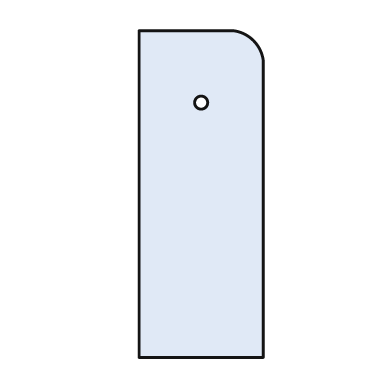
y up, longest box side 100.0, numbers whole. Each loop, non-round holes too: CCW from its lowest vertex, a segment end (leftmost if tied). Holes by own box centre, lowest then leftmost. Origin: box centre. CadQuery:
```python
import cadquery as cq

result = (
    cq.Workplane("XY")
    .moveTo(-19.0, -50.0)
    .lineTo(19.0, -50.0)
    .lineTo(19.0, 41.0)
    .threePointArc((16.0, 47.0), (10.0, 50.0))
    .lineTo(-19.0, 50.0)
    .close()
    .moveTo(0.0, 28.0)
    .circle(2.0)
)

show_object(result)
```